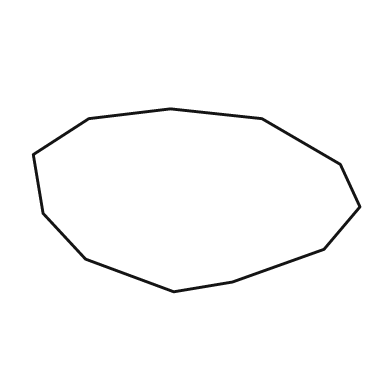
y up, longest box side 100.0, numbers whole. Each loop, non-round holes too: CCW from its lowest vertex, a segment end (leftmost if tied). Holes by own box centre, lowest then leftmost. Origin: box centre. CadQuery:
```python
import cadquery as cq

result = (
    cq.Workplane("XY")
    .moveTo(-7.0, -28.0)
    .lineTo(11.0, -25.0)
    .lineTo(39.0, -15.0)
    .lineTo(50.0, -2.0)
    .lineTo(44.0, 11.0)
    .lineTo(20.0, 25.0)
    .lineTo(-8.0, 28.0)
    .lineTo(-33.0, 25.0)
    .lineTo(-50.0, 14.0)
    .lineTo(-47.0, -4.0)
    .lineTo(-34.0, -18.0)
    .close()
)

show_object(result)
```